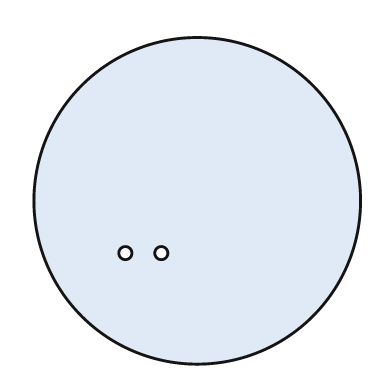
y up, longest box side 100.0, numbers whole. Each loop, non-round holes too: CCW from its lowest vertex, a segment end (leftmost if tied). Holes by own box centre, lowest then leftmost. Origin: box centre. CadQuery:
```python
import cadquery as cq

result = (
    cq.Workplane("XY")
    .moveTo(0.0, 0.0)
    .circle(50.0)
    .moveTo(-22.0, -16.0)
    .circle(2.0)
    .moveTo(-11.0, -16.0)
    .circle(2.0)
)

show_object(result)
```